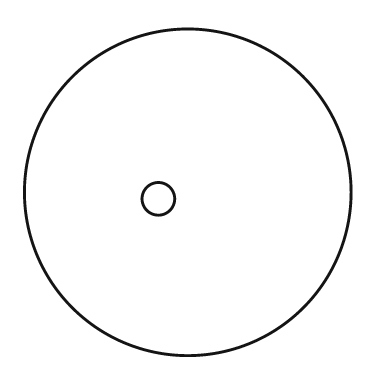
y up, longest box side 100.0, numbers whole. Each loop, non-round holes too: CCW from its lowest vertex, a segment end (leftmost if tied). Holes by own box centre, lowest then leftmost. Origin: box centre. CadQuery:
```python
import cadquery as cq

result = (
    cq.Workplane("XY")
    .moveTo(0.0, 0.0)
    .circle(50.0)
    .moveTo(-9.0, -2.0)
    .circle(5.0)
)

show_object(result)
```